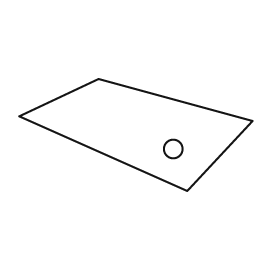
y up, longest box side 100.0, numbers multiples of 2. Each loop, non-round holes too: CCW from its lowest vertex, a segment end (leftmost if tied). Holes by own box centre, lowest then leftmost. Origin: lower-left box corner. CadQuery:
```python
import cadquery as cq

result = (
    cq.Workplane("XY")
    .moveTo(72.0, 0.0)
    .lineTo(100.0, 30.0)
    .lineTo(34.0, 48.0)
    .lineTo(0.0, 32.0)
    .close()
    .moveTo(66.0, 18.0)
    .circle(4.0)
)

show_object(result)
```